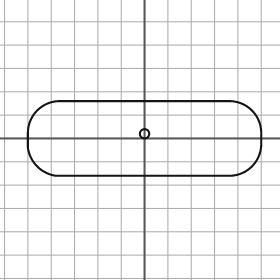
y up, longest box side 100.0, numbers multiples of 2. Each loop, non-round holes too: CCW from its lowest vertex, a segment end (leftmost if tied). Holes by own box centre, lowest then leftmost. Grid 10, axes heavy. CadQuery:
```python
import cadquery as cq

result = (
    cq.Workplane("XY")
    .moveTo(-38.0, -16.0)
    .lineTo(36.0, -16.0)
    .threePointArc((46.0, -12.0), (50.0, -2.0))
    .lineTo(50.0, 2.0)
    .threePointArc((46.0, 12.0), (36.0, 16.0))
    .lineTo(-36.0, 16.0)
    .threePointArc((-46.0, 12.0), (-50.0, 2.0))
    .lineTo(-50.0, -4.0)
    .threePointArc((-46.0, -12.0), (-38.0, -16.0))
    .close()
    .moveTo(0.0, 2.0)
    .circle(2.0)
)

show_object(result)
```